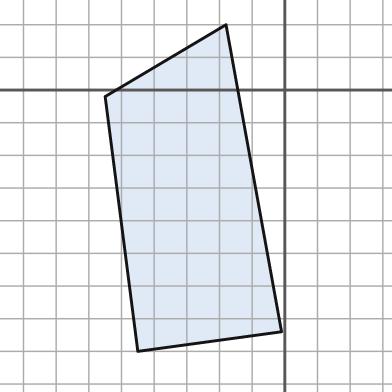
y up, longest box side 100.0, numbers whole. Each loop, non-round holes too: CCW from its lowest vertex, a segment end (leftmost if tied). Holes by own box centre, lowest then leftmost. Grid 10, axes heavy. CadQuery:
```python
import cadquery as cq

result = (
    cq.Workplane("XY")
    .moveTo(-45.0, -80.0)
    .lineTo(-1.0, -74.0)
    .lineTo(-18.0, 20.0)
    .lineTo(-55.0, -2.0)
    .close()
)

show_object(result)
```